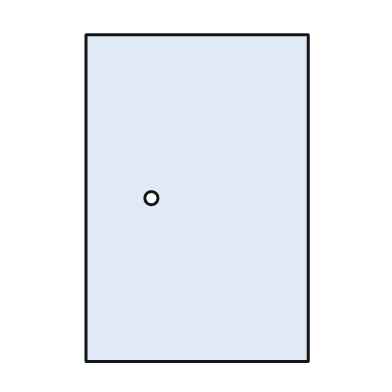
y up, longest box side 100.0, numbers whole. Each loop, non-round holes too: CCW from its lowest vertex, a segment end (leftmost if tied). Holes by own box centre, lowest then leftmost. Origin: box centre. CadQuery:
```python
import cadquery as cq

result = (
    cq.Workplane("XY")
    .moveTo(-34.0, -50.0)
    .lineTo(34.0, -50.0)
    .lineTo(34.0, 50.0)
    .lineTo(-34.0, 50.0)
    .close()
    .moveTo(-14.0, 0.0)
    .circle(2.0)
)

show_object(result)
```